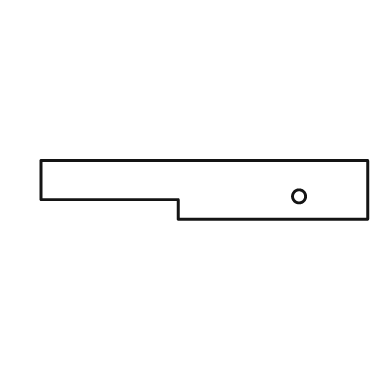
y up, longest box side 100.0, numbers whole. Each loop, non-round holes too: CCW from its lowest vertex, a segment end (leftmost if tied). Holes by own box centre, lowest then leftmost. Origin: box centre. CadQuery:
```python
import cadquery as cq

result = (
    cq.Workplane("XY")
    .moveTo(-8.0, -9.0)
    .lineTo(50.0, -9.0)
    .lineTo(50.0, 9.0)
    .lineTo(-50.0, 9.0)
    .lineTo(-50.0, -3.0)
    .lineTo(-8.0, -3.0)
    .close()
    .moveTo(29.0, -2.0)
    .circle(2.0)
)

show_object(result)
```